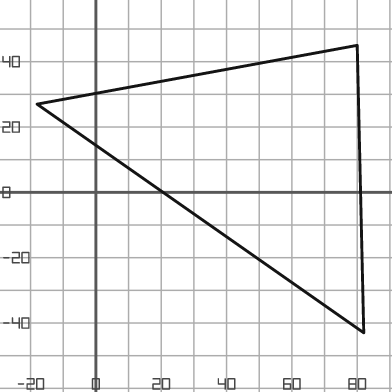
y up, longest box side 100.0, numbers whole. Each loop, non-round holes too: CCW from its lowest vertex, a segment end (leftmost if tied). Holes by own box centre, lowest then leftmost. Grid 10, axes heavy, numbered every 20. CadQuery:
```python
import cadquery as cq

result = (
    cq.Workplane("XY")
    .moveTo(82.0, -43.0)
    .lineTo(80.0, 45.0)
    .lineTo(-18.0, 27.0)
    .close()
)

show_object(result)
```